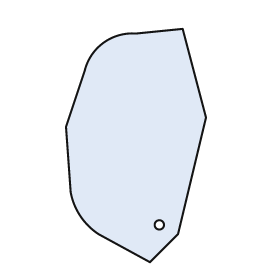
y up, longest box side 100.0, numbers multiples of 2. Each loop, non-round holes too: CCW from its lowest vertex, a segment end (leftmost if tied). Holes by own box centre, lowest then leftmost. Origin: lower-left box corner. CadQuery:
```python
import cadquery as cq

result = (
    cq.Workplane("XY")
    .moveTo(36.0, 0.0)
    .lineTo(48.0, 12.0)
    .lineTo(60.0, 62.0)
    .lineTo(50.0, 100.0)
    .lineTo(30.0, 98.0)
    .threePointArc((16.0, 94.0), (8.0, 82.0))
    .lineTo(0.0, 58.0)
    .lineTo(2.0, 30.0)
    .threePointArc((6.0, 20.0), (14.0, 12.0))
    .close()
    .moveTo(40.0, 16.0)
    .circle(2.0)
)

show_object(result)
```